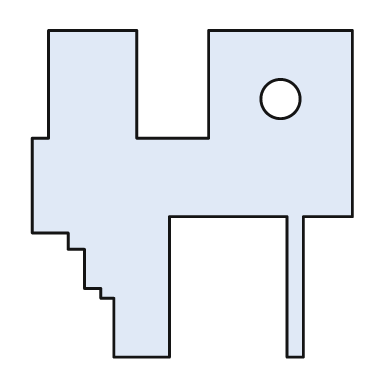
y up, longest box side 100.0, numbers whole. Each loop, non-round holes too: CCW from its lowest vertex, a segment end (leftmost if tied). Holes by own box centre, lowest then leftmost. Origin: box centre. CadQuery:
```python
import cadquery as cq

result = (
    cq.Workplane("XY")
    .moveTo(-24.0, -50.0)
    .lineTo(-7.0, -50.0)
    .lineTo(-7.0, -7.0)
    .lineTo(29.0, -7.0)
    .lineTo(29.0, -50.0)
    .lineTo(34.0, -50.0)
    .lineTo(34.0, -7.0)
    .lineTo(49.0, -7.0)
    .lineTo(49.0, 50.0)
    .lineTo(5.0, 50.0)
    .lineTo(5.0, 17.0)
    .lineTo(-17.0, 17.0)
    .lineTo(-17.0, 50.0)
    .lineTo(-44.0, 50.0)
    .lineTo(-44.0, 17.0)
    .lineTo(-49.0, 17.0)
    .lineTo(-49.0, -12.0)
    .lineTo(-38.0, -12.0)
    .lineTo(-38.0, -17.0)
    .lineTo(-33.0, -17.0)
    .lineTo(-33.0, -29.0)
    .lineTo(-28.0, -29.0)
    .lineTo(-28.0, -32.0)
    .lineTo(-24.0, -32.0)
    .close()
    .moveTo(27.0, 29.0)
    .circle(6.0)
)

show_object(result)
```